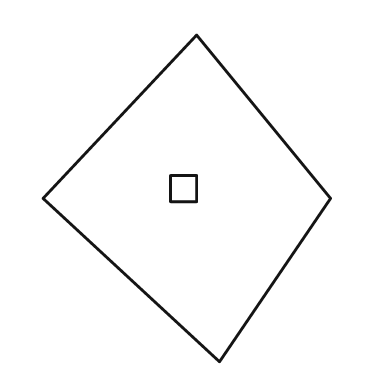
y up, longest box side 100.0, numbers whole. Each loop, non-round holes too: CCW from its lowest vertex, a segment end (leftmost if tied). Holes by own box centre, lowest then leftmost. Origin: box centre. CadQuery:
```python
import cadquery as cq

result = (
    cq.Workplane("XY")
    .moveTo(10.0, -50.0)
    .lineTo(44.0, 0.0)
    .lineTo(3.0, 50.0)
    .lineTo(-44.0, 0.0)
    .close()
    .moveTo(-5.0, -1.0)
    .lineTo(3.0, -1.0)
    .lineTo(3.0, 7.0)
    .lineTo(-5.0, 7.0)
    .close()
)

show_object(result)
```